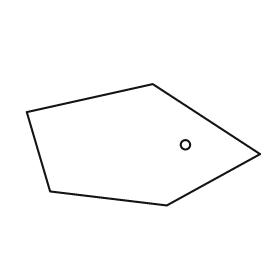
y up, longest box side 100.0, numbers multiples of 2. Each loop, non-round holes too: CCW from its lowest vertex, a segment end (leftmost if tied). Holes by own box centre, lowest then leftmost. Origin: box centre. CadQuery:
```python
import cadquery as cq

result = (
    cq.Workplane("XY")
    .moveTo(10.0, -26.0)
    .lineTo(50.0, -4.0)
    .lineTo(4.0, 26.0)
    .lineTo(-50.0, 14.0)
    .lineTo(-40.0, -20.0)
    .close()
    .moveTo(18.0, 0.0)
    .circle(2.0)
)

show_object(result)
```